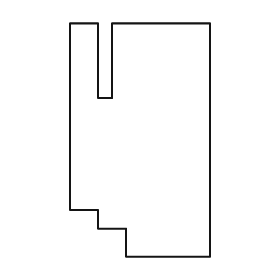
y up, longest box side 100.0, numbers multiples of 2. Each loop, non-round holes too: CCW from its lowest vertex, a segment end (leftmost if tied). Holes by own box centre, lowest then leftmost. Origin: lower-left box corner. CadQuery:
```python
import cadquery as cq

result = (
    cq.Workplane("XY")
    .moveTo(24.0, 0.0)
    .lineTo(60.0, 0.0)
    .lineTo(60.0, 100.0)
    .lineTo(18.0, 100.0)
    .lineTo(18.0, 68.0)
    .lineTo(12.0, 68.0)
    .lineTo(12.0, 100.0)
    .lineTo(0.0, 100.0)
    .lineTo(0.0, 20.0)
    .lineTo(12.0, 20.0)
    .lineTo(12.0, 12.0)
    .lineTo(24.0, 12.0)
    .close()
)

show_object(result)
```